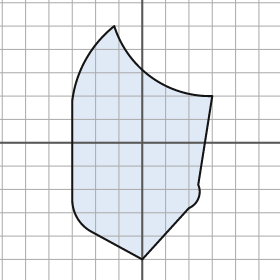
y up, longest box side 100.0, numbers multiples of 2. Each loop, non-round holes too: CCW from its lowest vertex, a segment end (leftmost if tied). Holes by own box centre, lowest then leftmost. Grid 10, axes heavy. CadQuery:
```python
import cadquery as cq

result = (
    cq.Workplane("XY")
    .moveTo(0.0, -50.0)
    .lineTo(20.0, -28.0)
    .threePointArc((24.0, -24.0), (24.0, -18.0))
    .lineTo(30.0, 20.0)
    .threePointArc((4.0, 28.0), (-12.0, 50.0))
    .threePointArc((-24.0, 36.0), (-30.0, 18.0))
    .lineTo(-30.0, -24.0)
    .threePointArc((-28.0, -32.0), (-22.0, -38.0))
    .close()
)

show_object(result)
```